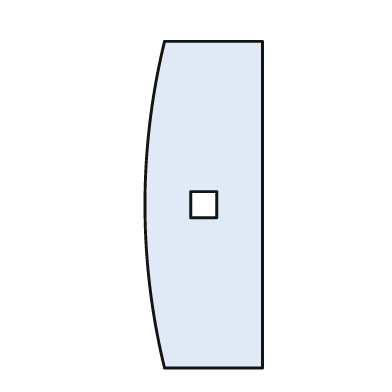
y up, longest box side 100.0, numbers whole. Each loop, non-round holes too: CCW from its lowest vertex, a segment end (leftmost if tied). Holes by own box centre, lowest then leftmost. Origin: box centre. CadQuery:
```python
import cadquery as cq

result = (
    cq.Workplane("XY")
    .moveTo(-12.0, -50.0)
    .lineTo(18.0, -50.0)
    .lineTo(18.0, 50.0)
    .lineTo(-12.0, 50.0)
    .threePointArc((-18.0, 0.0), (-12.0, -50.0))
    .close()
    .moveTo(-4.0, -4.0)
    .lineTo(4.0, -4.0)
    .lineTo(4.0, 4.0)
    .lineTo(-4.0, 4.0)
    .close()
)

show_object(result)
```